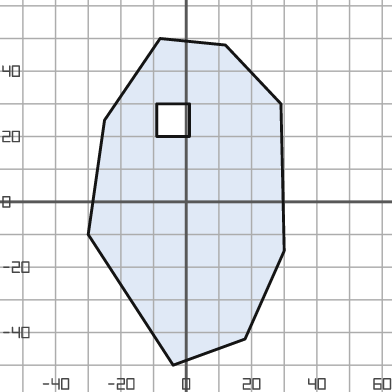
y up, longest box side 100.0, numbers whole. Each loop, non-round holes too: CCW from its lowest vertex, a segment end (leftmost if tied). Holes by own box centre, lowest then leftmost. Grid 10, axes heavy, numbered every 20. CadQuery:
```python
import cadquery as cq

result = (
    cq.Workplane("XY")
    .moveTo(-4.0, -50.0)
    .lineTo(18.0, -42.0)
    .lineTo(30.0, -15.0)
    .lineTo(29.0, 30.0)
    .lineTo(12.0, 48.0)
    .lineTo(-8.0, 50.0)
    .lineTo(-25.0, 25.0)
    .lineTo(-30.0, -10.0)
    .close()
    .moveTo(-9.0, 20.0)
    .lineTo(1.0, 20.0)
    .lineTo(1.0, 30.0)
    .lineTo(-9.0, 30.0)
    .close()
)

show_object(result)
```